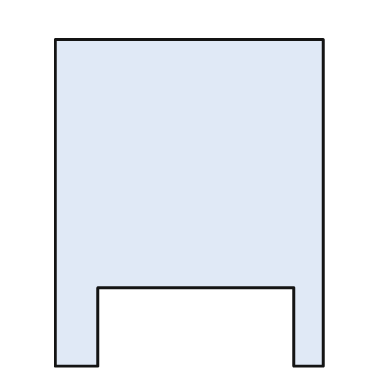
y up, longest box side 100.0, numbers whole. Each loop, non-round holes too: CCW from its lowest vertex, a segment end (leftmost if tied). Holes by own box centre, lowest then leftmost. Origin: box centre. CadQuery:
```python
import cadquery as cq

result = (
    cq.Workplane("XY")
    .moveTo(-41.0, -50.0)
    .lineTo(-28.0, -50.0)
    .lineTo(-28.0, -26.0)
    .lineTo(32.0, -26.0)
    .lineTo(32.0, -50.0)
    .lineTo(41.0, -50.0)
    .lineTo(41.0, 50.0)
    .lineTo(-41.0, 50.0)
    .close()
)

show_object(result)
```